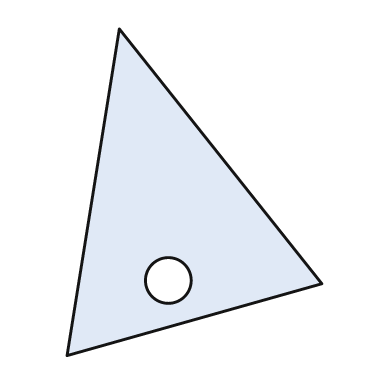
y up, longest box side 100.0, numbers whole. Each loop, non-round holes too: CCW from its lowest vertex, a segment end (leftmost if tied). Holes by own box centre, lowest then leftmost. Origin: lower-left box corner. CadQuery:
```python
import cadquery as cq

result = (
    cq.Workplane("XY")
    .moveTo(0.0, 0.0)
    .lineTo(78.0, 22.0)
    .lineTo(16.0, 100.0)
    .close()
    .moveTo(31.0, 23.0)
    .circle(7.0)
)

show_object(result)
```